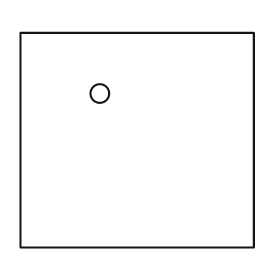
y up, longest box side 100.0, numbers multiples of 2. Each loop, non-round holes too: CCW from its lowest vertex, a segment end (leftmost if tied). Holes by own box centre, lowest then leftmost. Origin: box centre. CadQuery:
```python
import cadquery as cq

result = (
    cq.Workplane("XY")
    .moveTo(-50.0, -46.0)
    .lineTo(50.0, -46.0)
    .lineTo(50.0, 46.0)
    .lineTo(-50.0, 46.0)
    .close()
    .moveTo(-16.0, 20.0)
    .circle(4.0)
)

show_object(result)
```